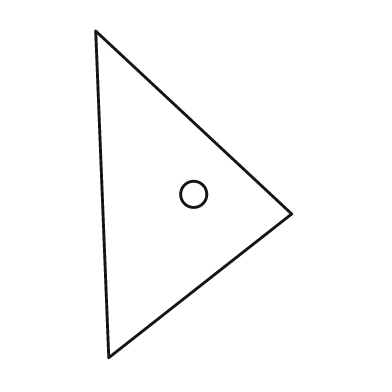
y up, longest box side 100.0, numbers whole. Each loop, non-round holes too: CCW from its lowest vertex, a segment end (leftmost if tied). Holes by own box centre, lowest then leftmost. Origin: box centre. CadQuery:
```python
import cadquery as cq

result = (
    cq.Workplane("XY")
    .moveTo(-26.0, -50.0)
    .lineTo(30.0, -6.0)
    .lineTo(-30.0, 50.0)
    .close()
    .moveTo(0.0, 0.0)
    .circle(4.0)
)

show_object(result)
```